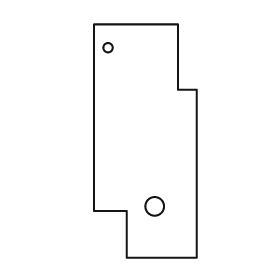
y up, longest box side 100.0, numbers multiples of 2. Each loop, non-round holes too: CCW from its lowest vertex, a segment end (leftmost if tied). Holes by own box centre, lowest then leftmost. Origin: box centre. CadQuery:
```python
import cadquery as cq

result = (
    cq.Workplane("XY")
    .moveTo(-8.0, -50.0)
    .lineTo(22.0, -50.0)
    .lineTo(22.0, 22.0)
    .lineTo(14.0, 22.0)
    .lineTo(14.0, 50.0)
    .lineTo(-22.0, 50.0)
    .lineTo(-22.0, -30.0)
    .lineTo(-8.0, -30.0)
    .close()
    .moveTo(4.0, -28.0)
    .circle(4.0)
    .moveTo(-16.0, 40.0)
    .circle(2.0)
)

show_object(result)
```